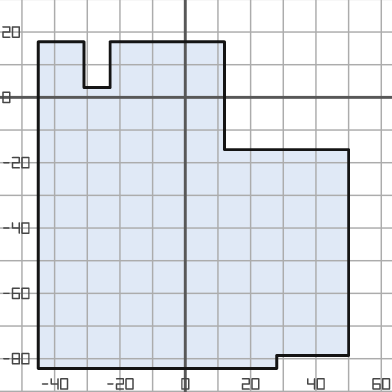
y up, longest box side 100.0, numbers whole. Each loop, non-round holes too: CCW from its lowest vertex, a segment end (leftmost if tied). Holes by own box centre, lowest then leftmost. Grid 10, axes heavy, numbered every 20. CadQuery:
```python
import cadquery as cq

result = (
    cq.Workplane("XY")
    .moveTo(-45.0, -83.0)
    .lineTo(28.0, -83.0)
    .lineTo(28.0, -79.0)
    .lineTo(50.0, -79.0)
    .lineTo(50.0, -16.0)
    .lineTo(12.0, -16.0)
    .lineTo(12.0, 17.0)
    .lineTo(-23.0, 17.0)
    .lineTo(-23.0, 3.0)
    .lineTo(-31.0, 3.0)
    .lineTo(-31.0, 17.0)
    .lineTo(-45.0, 17.0)
    .close()
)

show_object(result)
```